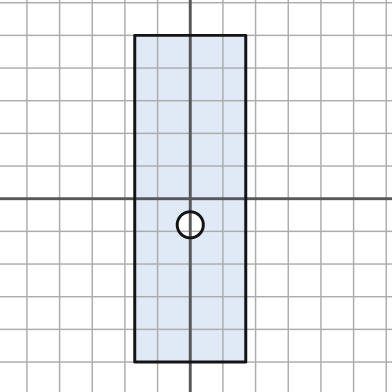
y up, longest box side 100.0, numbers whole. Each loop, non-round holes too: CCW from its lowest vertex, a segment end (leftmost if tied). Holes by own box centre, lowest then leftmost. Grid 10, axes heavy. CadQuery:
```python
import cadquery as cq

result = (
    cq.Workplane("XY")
    .moveTo(-17.0, -50.0)
    .lineTo(17.0, -50.0)
    .lineTo(17.0, 50.0)
    .lineTo(-17.0, 50.0)
    .close()
    .moveTo(0.0, -8.0)
    .circle(4.0)
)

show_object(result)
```